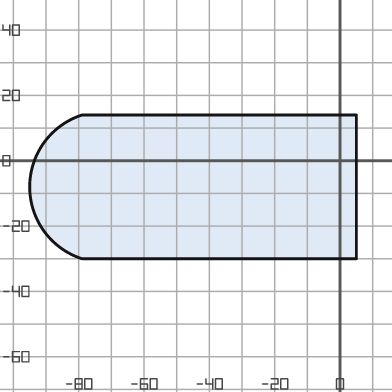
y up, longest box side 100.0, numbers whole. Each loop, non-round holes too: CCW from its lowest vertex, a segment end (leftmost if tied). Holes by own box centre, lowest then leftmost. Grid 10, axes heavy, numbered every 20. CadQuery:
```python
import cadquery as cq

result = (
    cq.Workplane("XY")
    .moveTo(-79.0, -30.0)
    .lineTo(5.0, -30.0)
    .lineTo(5.0, 14.0)
    .lineTo(-79.0, 14.0)
    .threePointArc((-95.0, -8.0), (-79.0, -30.0))
    .close()
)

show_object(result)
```